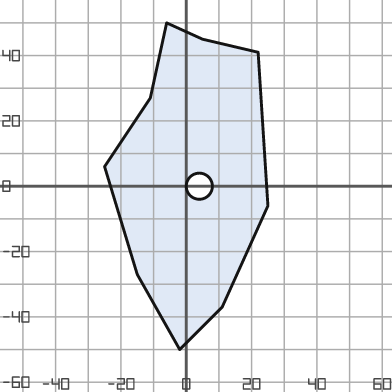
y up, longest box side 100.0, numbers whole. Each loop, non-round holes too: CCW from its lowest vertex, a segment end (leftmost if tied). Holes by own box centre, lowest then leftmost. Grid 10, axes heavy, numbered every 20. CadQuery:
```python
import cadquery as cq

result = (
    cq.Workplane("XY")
    .moveTo(-2.0, -50.0)
    .lineTo(11.0, -37.0)
    .lineTo(25.0, -6.0)
    .lineTo(22.0, 41.0)
    .lineTo(5.0, 45.0)
    .lineTo(-6.0, 50.0)
    .lineTo(-11.0, 27.0)
    .lineTo(-25.0, 6.0)
    .lineTo(-15.0, -27.0)
    .close()
    .moveTo(4.0, 0.0)
    .circle(4.0)
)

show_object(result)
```